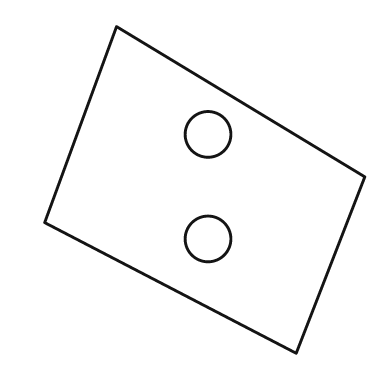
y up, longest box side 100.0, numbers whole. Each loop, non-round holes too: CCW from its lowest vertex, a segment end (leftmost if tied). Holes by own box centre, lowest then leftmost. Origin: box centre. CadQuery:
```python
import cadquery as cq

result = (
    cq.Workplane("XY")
    .moveTo(28.0, -50.0)
    .lineTo(49.0, 4.0)
    .lineTo(-27.0, 50.0)
    .lineTo(-49.0, -10.0)
    .close()
    .moveTo(1.0, -15.0)
    .circle(7.0)
    .moveTo(1.0, 17.0)
    .circle(7.0)
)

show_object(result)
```